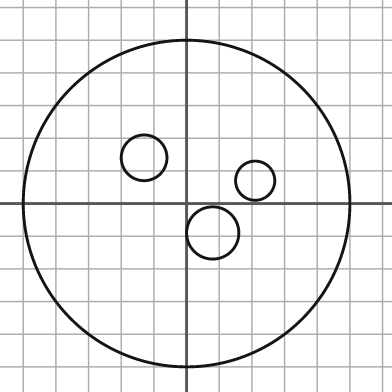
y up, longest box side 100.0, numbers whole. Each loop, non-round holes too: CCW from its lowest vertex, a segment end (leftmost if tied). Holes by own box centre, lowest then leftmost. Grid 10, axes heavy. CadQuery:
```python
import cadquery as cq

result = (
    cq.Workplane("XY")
    .moveTo(0.0, 0.0)
    .circle(50.0)
    .moveTo(8.0, -9.0)
    .circle(8.0)
    .moveTo(21.0, 7.0)
    .circle(6.0)
    .moveTo(-13.0, 14.0)
    .circle(7.0)
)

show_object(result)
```